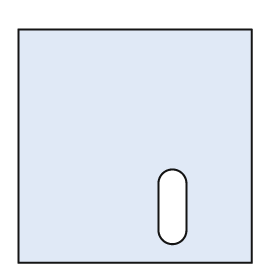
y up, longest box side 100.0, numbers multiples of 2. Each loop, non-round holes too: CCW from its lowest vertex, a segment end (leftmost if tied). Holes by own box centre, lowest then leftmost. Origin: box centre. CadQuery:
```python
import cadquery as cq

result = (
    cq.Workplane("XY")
    .moveTo(-50.0, -50.0)
    .lineTo(50.0, -50.0)
    .lineTo(50.0, 50.0)
    .lineTo(-50.0, 50.0)
    .close()
    .moveTo(10.0, -36.0)
    .threePointArc((16.0, -42.0), (22.0, -36.0))
    .lineTo(22.0, -16.0)
    .threePointArc((16.0, -10.0), (10.0, -16.0))
    .close()
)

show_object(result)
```